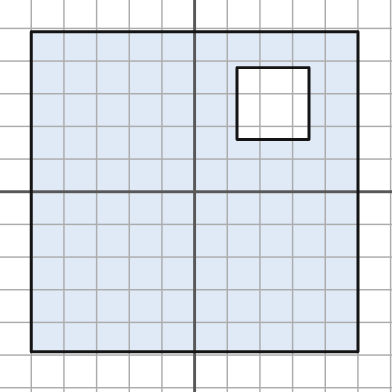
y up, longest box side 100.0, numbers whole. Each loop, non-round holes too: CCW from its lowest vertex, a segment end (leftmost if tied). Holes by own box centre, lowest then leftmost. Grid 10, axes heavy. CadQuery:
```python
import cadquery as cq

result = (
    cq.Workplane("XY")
    .moveTo(-50.0, -49.0)
    .lineTo(50.0, -49.0)
    .lineTo(50.0, 49.0)
    .lineTo(-50.0, 49.0)
    .close()
    .moveTo(13.0, 16.0)
    .lineTo(35.0, 16.0)
    .lineTo(35.0, 38.0)
    .lineTo(13.0, 38.0)
    .close()
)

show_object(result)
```